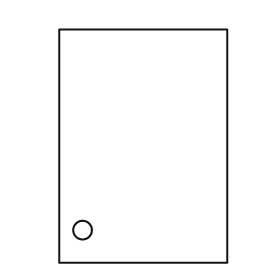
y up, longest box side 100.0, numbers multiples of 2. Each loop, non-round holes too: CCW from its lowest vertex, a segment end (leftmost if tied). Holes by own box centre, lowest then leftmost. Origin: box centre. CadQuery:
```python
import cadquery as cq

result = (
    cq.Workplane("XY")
    .moveTo(-36.0, -50.0)
    .lineTo(36.0, -50.0)
    .lineTo(36.0, 50.0)
    .lineTo(-36.0, 50.0)
    .close()
    .moveTo(-26.0, -36.0)
    .circle(4.0)
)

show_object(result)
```